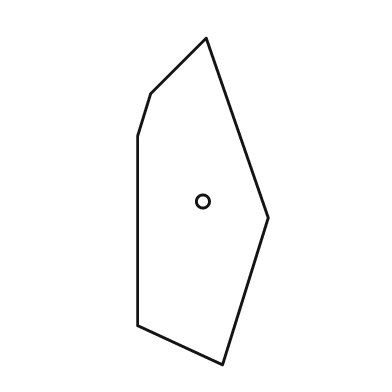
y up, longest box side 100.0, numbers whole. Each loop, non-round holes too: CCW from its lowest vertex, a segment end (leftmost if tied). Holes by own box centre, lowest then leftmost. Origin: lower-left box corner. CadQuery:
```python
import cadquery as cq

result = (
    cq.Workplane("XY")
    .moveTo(26.0, 0.0)
    .lineTo(40.0, 45.0)
    .lineTo(21.0, 100.0)
    .lineTo(4.0, 83.0)
    .lineTo(0.0, 70.0)
    .lineTo(0.0, 12.0)
    .close()
    .moveTo(20.0, 50.0)
    .circle(2.0)
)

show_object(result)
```